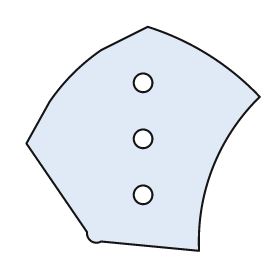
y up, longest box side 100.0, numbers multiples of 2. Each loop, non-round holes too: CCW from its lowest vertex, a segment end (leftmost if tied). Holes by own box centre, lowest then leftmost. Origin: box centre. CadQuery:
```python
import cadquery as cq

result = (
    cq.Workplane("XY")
    .moveTo(24.0, -48.0)
    .threePointArc((30.0, -12.0), (50.0, 18.0))
    .threePointArc((28.0, 36.0), (2.0, 48.0))
    .lineTo(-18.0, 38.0)
    .threePointArc((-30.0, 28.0), (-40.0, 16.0))
    .lineTo(-50.0, -2.0)
    .lineTo(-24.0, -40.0)
    .threePointArc((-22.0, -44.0), (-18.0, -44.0))
    .close()
    .moveTo(0.0, -24.0)
    .circle(4.0)
    .moveTo(0.0, 0.0)
    .circle(4.0)
    .moveTo(0.0, 24.0)
    .circle(4.0)
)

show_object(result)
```